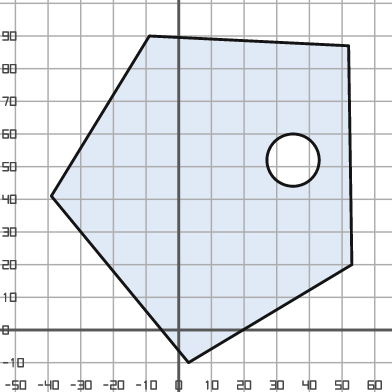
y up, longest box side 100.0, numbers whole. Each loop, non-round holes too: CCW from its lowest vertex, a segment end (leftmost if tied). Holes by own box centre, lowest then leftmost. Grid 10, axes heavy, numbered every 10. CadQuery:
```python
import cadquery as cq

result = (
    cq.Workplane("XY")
    .moveTo(3.0, -10.0)
    .lineTo(53.0, 20.0)
    .lineTo(52.0, 87.0)
    .lineTo(-9.0, 90.0)
    .lineTo(-39.0, 41.0)
    .close()
    .moveTo(35.0, 52.0)
    .circle(8.0)
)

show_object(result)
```